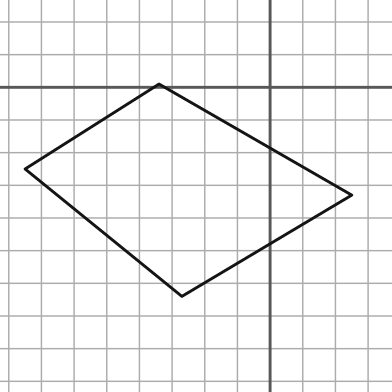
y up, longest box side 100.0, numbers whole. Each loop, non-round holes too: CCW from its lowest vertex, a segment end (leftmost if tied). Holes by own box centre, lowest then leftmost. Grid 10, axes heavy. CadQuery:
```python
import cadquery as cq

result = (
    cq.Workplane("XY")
    .moveTo(-27.0, -64.0)
    .lineTo(25.0, -33.0)
    .lineTo(-34.0, 1.0)
    .lineTo(-75.0, -25.0)
    .close()
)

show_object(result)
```